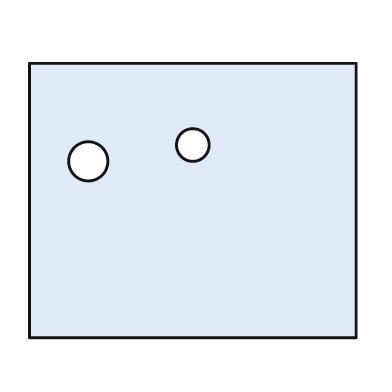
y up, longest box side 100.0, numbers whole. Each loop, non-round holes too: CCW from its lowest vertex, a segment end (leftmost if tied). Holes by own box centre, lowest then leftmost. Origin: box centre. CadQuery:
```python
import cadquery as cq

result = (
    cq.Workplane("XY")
    .moveTo(-50.0, -42.0)
    .lineTo(50.0, -42.0)
    .lineTo(50.0, 42.0)
    .lineTo(-50.0, 42.0)
    .close()
    .moveTo(-32.0, 12.0)
    .circle(6.0)
    .moveTo(0.0, 17.0)
    .circle(5.0)
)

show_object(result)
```